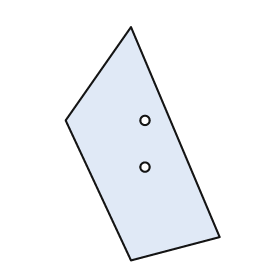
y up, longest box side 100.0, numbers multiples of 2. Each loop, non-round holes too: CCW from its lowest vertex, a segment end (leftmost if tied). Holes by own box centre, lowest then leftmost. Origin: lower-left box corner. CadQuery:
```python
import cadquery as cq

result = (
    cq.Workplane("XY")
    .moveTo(28.0, 0.0)
    .lineTo(66.0, 10.0)
    .lineTo(28.0, 100.0)
    .lineTo(0.0, 60.0)
    .close()
    .moveTo(34.0, 40.0)
    .circle(2.0)
    .moveTo(34.0, 60.0)
    .circle(2.0)
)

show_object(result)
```